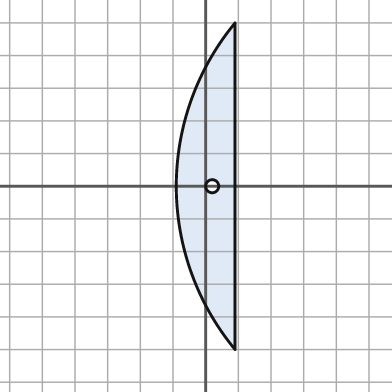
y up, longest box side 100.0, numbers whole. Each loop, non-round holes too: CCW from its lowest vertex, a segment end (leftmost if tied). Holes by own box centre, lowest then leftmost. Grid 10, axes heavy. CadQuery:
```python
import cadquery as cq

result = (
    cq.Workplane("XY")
    .moveTo(9.0, -50.0)
    .lineTo(9.0, 50.0)
    .threePointArc((-9.0, 0.0), (9.0, -50.0))
    .close()
    .moveTo(2.0, 0.0)
    .circle(2.0)
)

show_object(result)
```